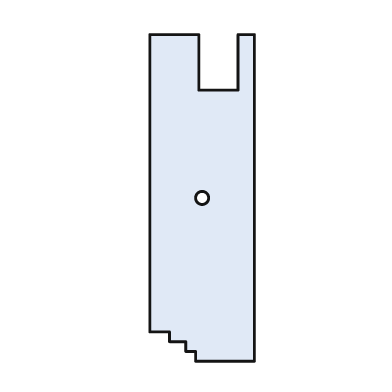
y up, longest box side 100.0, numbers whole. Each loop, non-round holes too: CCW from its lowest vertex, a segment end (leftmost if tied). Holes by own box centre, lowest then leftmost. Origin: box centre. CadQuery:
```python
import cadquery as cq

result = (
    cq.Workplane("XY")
    .moveTo(-2.0, -50.0)
    .lineTo(16.0, -50.0)
    .lineTo(16.0, 50.0)
    .lineTo(11.0, 50.0)
    .lineTo(11.0, 33.0)
    .lineTo(-1.0, 33.0)
    .lineTo(-1.0, 50.0)
    .lineTo(-16.0, 50.0)
    .lineTo(-16.0, -41.0)
    .lineTo(-10.0, -41.0)
    .lineTo(-10.0, -44.0)
    .lineTo(-5.0, -44.0)
    .lineTo(-5.0, -47.0)
    .lineTo(-2.0, -47.0)
    .close()
    .moveTo(0.0, 0.0)
    .circle(2.0)
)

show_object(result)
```